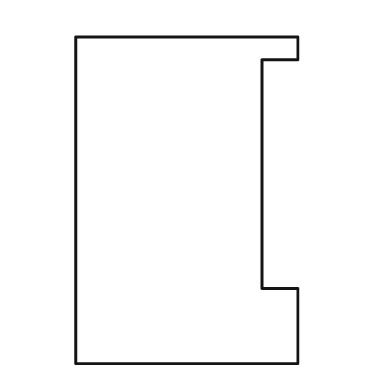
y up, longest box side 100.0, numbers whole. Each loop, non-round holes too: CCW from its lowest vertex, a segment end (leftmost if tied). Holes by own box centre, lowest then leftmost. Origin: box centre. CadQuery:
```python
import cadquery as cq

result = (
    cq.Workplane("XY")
    .moveTo(-34.0, -50.0)
    .lineTo(34.0, -50.0)
    .lineTo(34.0, -27.0)
    .lineTo(23.0, -27.0)
    .lineTo(23.0, 43.0)
    .lineTo(34.0, 43.0)
    .lineTo(34.0, 50.0)
    .lineTo(-34.0, 50.0)
    .close()
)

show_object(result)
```